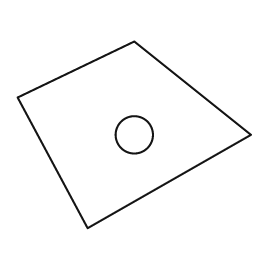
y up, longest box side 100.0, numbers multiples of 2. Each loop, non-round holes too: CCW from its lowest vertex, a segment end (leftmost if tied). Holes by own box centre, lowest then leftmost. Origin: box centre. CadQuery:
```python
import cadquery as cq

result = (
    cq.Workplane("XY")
    .moveTo(-20.0, -40.0)
    .lineTo(50.0, 0.0)
    .lineTo(0.0, 40.0)
    .lineTo(-50.0, 16.0)
    .close()
    .moveTo(0.0, 0.0)
    .circle(8.0)
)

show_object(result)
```